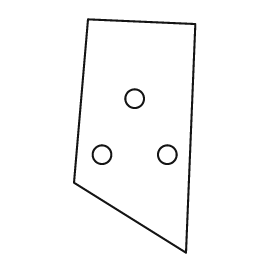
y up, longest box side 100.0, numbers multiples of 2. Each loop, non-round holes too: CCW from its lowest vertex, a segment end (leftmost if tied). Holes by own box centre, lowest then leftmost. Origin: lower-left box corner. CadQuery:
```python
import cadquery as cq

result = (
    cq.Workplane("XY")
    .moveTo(48.0, 0.0)
    .lineTo(52.0, 98.0)
    .lineTo(6.0, 100.0)
    .lineTo(0.0, 30.0)
    .close()
    .moveTo(12.0, 42.0)
    .circle(4.0)
    .moveTo(40.0, 42.0)
    .circle(4.0)
    .moveTo(26.0, 66.0)
    .circle(4.0)
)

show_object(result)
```